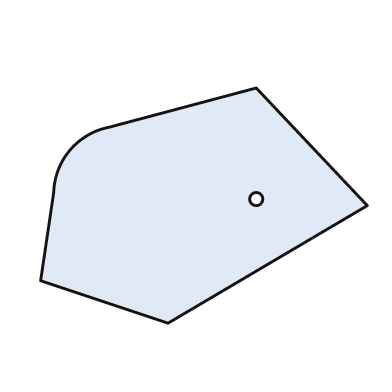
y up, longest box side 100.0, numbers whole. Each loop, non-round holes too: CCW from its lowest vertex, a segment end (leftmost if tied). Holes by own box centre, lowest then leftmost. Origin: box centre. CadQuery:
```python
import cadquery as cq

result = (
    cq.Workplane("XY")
    .moveTo(-11.0, -36.0)
    .lineTo(50.0, 0.0)
    .lineTo(16.0, 36.0)
    .lineTo(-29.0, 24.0)
    .threePointArc((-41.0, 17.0), (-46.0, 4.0))
    .lineTo(-50.0, -23.0)
    .close()
    .moveTo(16.0, 2.0)
    .circle(2.0)
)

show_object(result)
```